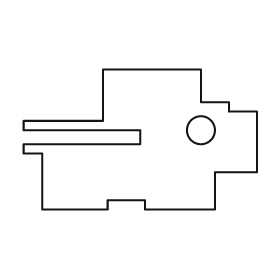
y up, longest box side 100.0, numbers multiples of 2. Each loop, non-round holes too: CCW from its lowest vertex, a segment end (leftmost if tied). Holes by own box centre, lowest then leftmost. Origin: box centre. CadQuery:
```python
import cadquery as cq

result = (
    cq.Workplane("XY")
    .moveTo(-42.0, -30.0)
    .lineTo(-14.0, -30.0)
    .lineTo(-14.0, -26.0)
    .lineTo(2.0, -26.0)
    .lineTo(2.0, -30.0)
    .lineTo(32.0, -30.0)
    .lineTo(32.0, -14.0)
    .lineTo(50.0, -14.0)
    .lineTo(50.0, 12.0)
    .lineTo(38.0, 12.0)
    .lineTo(38.0, 16.0)
    .lineTo(26.0, 16.0)
    .lineTo(26.0, 30.0)
    .lineTo(-16.0, 30.0)
    .lineTo(-16.0, 8.0)
    .lineTo(-50.0, 8.0)
    .lineTo(-50.0, 4.0)
    .lineTo(0.0, 4.0)
    .lineTo(0.0, -2.0)
    .lineTo(-50.0, -2.0)
    .lineTo(-50.0, -6.0)
    .lineTo(-42.0, -6.0)
    .close()
    .moveTo(26.0, 4.0)
    .circle(6.0)
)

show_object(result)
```